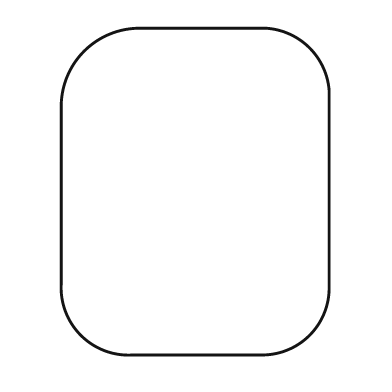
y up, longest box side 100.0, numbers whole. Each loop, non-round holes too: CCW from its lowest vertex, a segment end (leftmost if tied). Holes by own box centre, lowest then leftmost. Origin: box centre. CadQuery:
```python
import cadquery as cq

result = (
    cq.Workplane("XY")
    .moveTo(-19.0, -50.0)
    .lineTo(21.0, -50.0)
    .threePointArc((35.0, -44.0), (41.0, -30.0))
    .lineTo(41.0, 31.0)
    .threePointArc((35.0, 44.0), (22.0, 50.0))
    .lineTo(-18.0, 50.0)
    .threePointArc((-34.0, 43.0), (-41.0, 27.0))
    .lineTo(-41.0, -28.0)
    .threePointArc((-35.0, -44.0), (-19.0, -50.0))
    .close()
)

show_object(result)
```